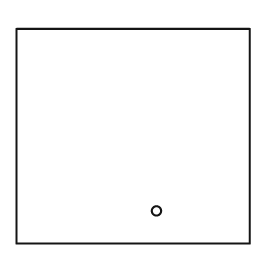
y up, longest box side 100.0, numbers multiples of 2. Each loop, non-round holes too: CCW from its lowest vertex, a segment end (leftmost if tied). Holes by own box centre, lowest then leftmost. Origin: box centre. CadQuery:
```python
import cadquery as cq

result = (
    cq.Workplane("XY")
    .moveTo(-50.0, -46.0)
    .lineTo(50.0, -46.0)
    .lineTo(50.0, 46.0)
    .lineTo(-50.0, 46.0)
    .close()
    .moveTo(10.0, -32.0)
    .circle(2.0)
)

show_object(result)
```